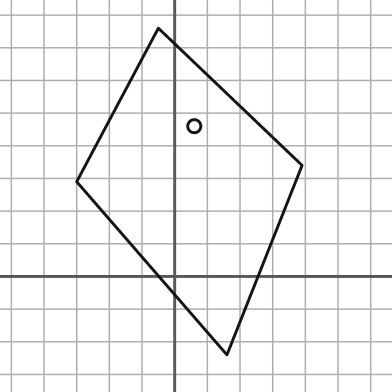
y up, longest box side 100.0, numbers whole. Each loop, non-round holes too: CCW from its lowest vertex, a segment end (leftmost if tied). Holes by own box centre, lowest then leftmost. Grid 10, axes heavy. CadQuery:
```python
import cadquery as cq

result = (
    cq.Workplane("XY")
    .moveTo(16.0, -24.0)
    .lineTo(39.0, 34.0)
    .lineTo(-5.0, 76.0)
    .lineTo(-30.0, 29.0)
    .close()
    .moveTo(6.0, 46.0)
    .circle(2.0)
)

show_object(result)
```